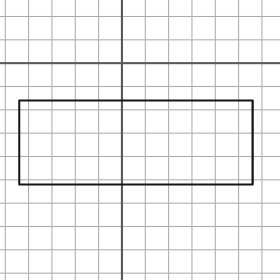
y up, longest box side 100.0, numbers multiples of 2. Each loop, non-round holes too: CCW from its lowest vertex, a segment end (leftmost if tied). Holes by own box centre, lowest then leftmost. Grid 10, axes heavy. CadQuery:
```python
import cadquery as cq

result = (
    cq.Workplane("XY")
    .moveTo(-44.0, -52.0)
    .lineTo(56.0, -52.0)
    .lineTo(56.0, -16.0)
    .lineTo(-44.0, -16.0)
    .close()
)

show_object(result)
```